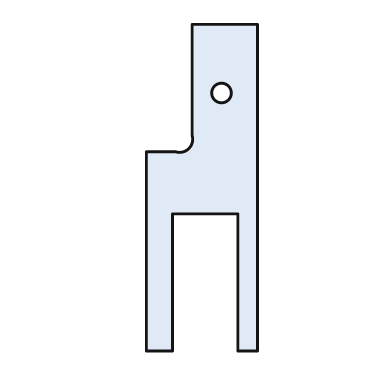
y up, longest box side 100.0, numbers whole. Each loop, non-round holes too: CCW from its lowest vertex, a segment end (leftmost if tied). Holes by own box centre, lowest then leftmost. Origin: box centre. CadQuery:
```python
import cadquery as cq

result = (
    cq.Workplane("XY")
    .moveTo(-17.0, -50.0)
    .lineTo(-9.0, -50.0)
    .lineTo(-9.0, -8.0)
    .lineTo(11.0, -8.0)
    .lineTo(11.0, -50.0)
    .lineTo(17.0, -50.0)
    .lineTo(17.0, 50.0)
    .lineTo(-3.0, 50.0)
    .lineTo(-3.0, 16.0)
    .threePointArc((-4.0, 12.0), (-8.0, 11.0))
    .lineTo(-17.0, 11.0)
    .close()
    .moveTo(6.0, 29.0)
    .circle(3.0)
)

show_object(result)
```